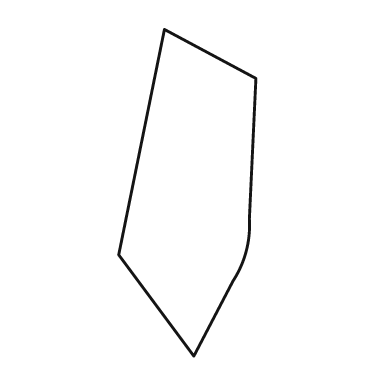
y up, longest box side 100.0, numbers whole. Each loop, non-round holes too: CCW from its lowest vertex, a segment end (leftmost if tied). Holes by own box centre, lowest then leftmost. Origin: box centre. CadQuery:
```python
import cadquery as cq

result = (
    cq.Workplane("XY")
    .moveTo(2.0, -50.0)
    .lineTo(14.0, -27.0)
    .threePointArc((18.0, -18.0), (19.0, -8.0))
    .lineTo(21.0, 35.0)
    .lineTo(-7.0, 50.0)
    .lineTo(-21.0, -19.0)
    .close()
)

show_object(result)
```